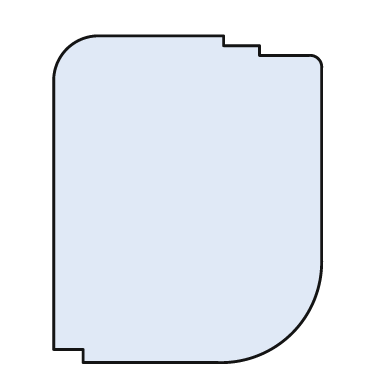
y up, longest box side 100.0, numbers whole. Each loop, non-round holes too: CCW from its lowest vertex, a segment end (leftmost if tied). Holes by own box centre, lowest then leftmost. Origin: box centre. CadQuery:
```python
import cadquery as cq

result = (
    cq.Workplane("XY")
    .moveTo(-32.0, -50.0)
    .lineTo(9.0, -50.0)
    .threePointArc((32.0, -41.0), (41.0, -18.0))
    .lineTo(41.0, 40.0)
    .threePointArc((40.0, 43.0), (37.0, 44.0))
    .lineTo(22.0, 44.0)
    .lineTo(22.0, 47.0)
    .lineTo(11.0, 47.0)
    .lineTo(11.0, 50.0)
    .lineTo(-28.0, 50.0)
    .threePointArc((-37.0, 46.0), (-41.0, 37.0))
    .lineTo(-41.0, -46.0)
    .lineTo(-32.0, -46.0)
    .close()
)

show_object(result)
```